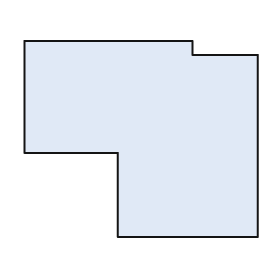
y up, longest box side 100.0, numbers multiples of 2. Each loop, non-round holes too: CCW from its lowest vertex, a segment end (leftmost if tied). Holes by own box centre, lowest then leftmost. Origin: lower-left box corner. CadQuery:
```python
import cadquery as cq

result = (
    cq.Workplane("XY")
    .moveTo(40.0, 0.0)
    .lineTo(100.0, 0.0)
    .lineTo(100.0, 78.0)
    .lineTo(72.0, 78.0)
    .lineTo(72.0, 84.0)
    .lineTo(0.0, 84.0)
    .lineTo(0.0, 36.0)
    .lineTo(40.0, 36.0)
    .close()
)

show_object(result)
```